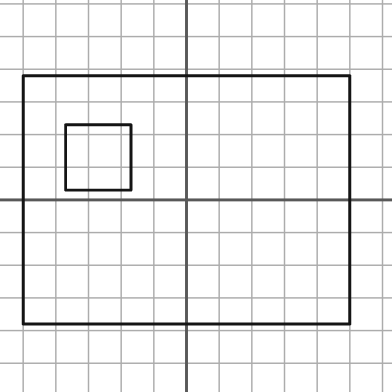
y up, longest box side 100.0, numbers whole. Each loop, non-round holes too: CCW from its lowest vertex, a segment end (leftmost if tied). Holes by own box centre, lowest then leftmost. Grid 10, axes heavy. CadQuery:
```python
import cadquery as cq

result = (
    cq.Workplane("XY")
    .moveTo(-50.0, -38.0)
    .lineTo(50.0, -38.0)
    .lineTo(50.0, 38.0)
    .lineTo(-50.0, 38.0)
    .close()
    .moveTo(-37.0, 3.0)
    .lineTo(-17.0, 3.0)
    .lineTo(-17.0, 23.0)
    .lineTo(-37.0, 23.0)
    .close()
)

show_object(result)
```